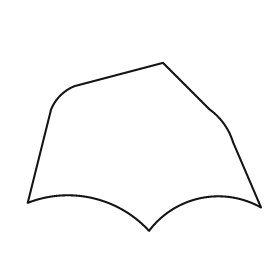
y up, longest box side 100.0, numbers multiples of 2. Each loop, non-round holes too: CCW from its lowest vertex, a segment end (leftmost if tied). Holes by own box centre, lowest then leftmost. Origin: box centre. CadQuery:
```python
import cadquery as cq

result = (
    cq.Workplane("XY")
    .moveTo(2.0, -36.0)
    .threePointArc((24.0, -22.0), (50.0, -26.0))
    .lineTo(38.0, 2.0)
    .threePointArc((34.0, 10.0), (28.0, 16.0))
    .lineTo(8.0, 36.0)
    .lineTo(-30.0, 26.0)
    .threePointArc((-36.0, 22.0), (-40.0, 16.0))
    .lineTo(-50.0, -24.0)
    .threePointArc((-22.0, -22.0), (2.0, -36.0))
    .close()
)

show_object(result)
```